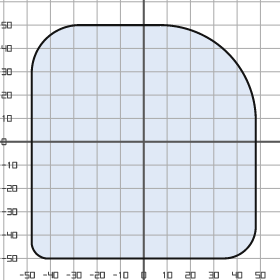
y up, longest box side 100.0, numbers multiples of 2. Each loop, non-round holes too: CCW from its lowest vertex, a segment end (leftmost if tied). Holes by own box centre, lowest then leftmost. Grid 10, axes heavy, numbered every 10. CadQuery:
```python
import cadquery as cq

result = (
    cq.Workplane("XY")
    .moveTo(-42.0, -50.0)
    .lineTo(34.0, -50.0)
    .threePointArc((44.0, -46.0), (48.0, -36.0))
    .lineTo(48.0, 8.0)
    .threePointArc((36.0, 38.0), (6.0, 50.0))
    .lineTo(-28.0, 50.0)
    .threePointArc((-42.0, 44.0), (-48.0, 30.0))
    .lineTo(-48.0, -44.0)
    .threePointArc((-46.0, -48.0), (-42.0, -50.0))
    .close()
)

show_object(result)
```